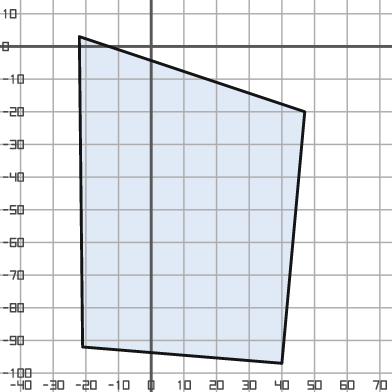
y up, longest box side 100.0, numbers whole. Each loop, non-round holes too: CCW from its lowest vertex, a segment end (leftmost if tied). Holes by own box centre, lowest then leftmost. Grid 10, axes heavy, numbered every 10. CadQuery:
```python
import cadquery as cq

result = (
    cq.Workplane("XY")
    .moveTo(40.0, -97.0)
    .lineTo(47.0, -20.0)
    .lineTo(-22.0, 3.0)
    .lineTo(-21.0, -92.0)
    .close()
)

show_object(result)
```